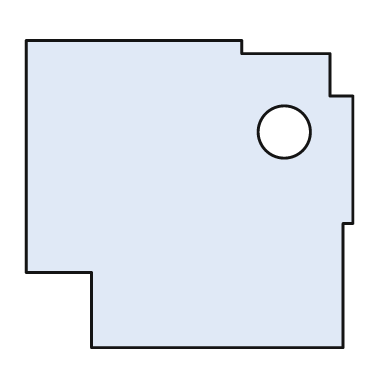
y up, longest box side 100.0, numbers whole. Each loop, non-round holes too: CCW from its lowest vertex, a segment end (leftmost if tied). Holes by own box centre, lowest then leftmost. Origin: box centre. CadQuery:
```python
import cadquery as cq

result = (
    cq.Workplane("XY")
    .moveTo(-30.0, -47.0)
    .lineTo(47.0, -47.0)
    .lineTo(47.0, -9.0)
    .lineTo(50.0, -9.0)
    .lineTo(50.0, 30.0)
    .lineTo(43.0, 30.0)
    .lineTo(43.0, 43.0)
    .lineTo(16.0, 43.0)
    .lineTo(16.0, 47.0)
    .lineTo(-50.0, 47.0)
    .lineTo(-50.0, -24.0)
    .lineTo(-30.0, -24.0)
    .close()
    .moveTo(29.0, 19.0)
    .circle(8.0)
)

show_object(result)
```